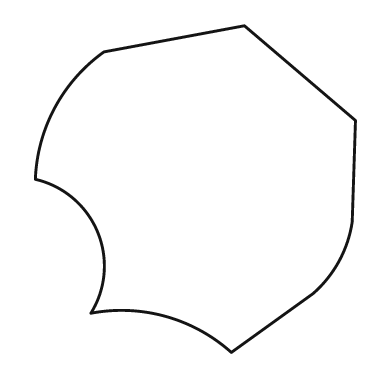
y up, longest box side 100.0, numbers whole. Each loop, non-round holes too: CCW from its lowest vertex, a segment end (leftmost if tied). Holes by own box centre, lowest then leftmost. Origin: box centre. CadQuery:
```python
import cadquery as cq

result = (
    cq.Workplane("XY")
    .moveTo(11.0, -50.0)
    .lineTo(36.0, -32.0)
    .threePointArc((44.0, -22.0), (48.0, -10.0))
    .lineTo(49.0, 21.0)
    .lineTo(15.0, 50.0)
    .lineTo(-28.0, 42.0)
    .threePointArc((-43.0, 25.0), (-49.0, 3.0))
    .threePointArc((-30.0, -13.0), (-32.0, -38.0))
    .threePointArc((-9.0, -39.0), (11.0, -50.0))
    .close()
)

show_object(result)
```